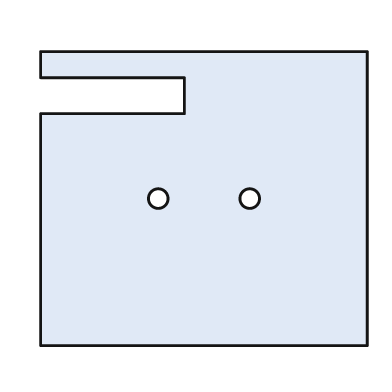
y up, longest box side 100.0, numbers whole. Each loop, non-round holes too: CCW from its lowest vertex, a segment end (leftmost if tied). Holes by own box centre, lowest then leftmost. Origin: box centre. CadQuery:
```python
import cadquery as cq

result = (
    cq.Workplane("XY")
    .moveTo(-50.0, -45.0)
    .lineTo(50.0, -45.0)
    .lineTo(50.0, 45.0)
    .lineTo(-50.0, 45.0)
    .lineTo(-50.0, 37.0)
    .lineTo(-6.0, 37.0)
    .lineTo(-6.0, 26.0)
    .lineTo(-50.0, 26.0)
    .close()
    .moveTo(-14.0, 0.0)
    .circle(3.0)
    .moveTo(14.0, 0.0)
    .circle(3.0)
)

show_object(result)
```